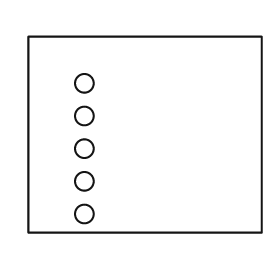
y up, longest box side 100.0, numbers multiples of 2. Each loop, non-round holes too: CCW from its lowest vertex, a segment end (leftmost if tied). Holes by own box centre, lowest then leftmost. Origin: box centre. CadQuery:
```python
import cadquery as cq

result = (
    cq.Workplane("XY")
    .moveTo(-50.0, -42.0)
    .lineTo(50.0, -42.0)
    .lineTo(50.0, 42.0)
    .lineTo(-50.0, 42.0)
    .close()
    .moveTo(-26.0, -34.0)
    .circle(4.0)
    .moveTo(-26.0, -20.0)
    .circle(4.0)
    .moveTo(-26.0, -6.0)
    .circle(4.0)
    .moveTo(-26.0, 8.0)
    .circle(4.0)
    .moveTo(-26.0, 22.0)
    .circle(4.0)
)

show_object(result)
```